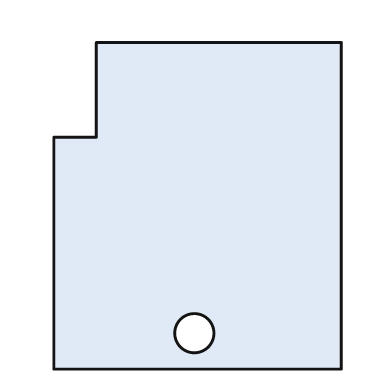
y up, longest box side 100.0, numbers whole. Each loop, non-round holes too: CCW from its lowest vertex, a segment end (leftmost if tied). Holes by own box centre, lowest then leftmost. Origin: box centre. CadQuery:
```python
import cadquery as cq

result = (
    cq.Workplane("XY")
    .moveTo(-44.0, -50.0)
    .lineTo(44.0, -50.0)
    .lineTo(44.0, 50.0)
    .lineTo(-31.0, 50.0)
    .lineTo(-31.0, 21.0)
    .lineTo(-44.0, 21.0)
    .close()
    .moveTo(-1.0, -39.0)
    .circle(6.0)
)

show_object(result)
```